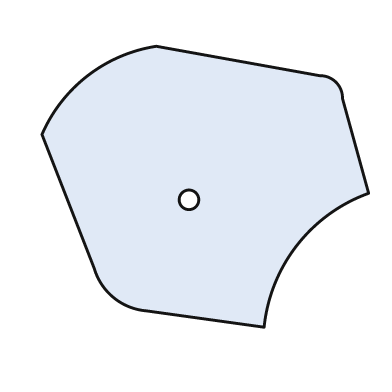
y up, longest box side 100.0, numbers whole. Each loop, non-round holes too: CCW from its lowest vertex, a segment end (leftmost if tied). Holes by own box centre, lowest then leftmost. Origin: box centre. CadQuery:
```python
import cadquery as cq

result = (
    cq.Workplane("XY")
    .moveTo(18.0, -43.0)
    .threePointArc((28.0, -18.0), (50.0, -2.0))
    .lineTo(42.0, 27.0)
    .threePointArc((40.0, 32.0), (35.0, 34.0))
    .lineTo(-15.0, 43.0)
    .threePointArc((-36.0, 34.0), (-50.0, 16.0))
    .lineTo(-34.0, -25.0)
    .threePointArc((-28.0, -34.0), (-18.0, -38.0))
    .close()
    .moveTo(-5.0, -4.0)
    .circle(3.0)
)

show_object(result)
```